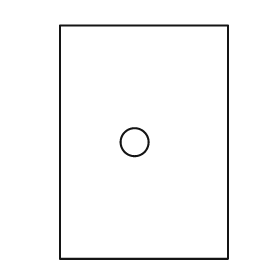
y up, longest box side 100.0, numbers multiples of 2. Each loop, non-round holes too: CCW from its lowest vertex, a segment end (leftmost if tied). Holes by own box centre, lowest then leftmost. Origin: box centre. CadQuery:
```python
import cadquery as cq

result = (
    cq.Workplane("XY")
    .moveTo(-36.0, -50.0)
    .lineTo(36.0, -50.0)
    .lineTo(36.0, 50.0)
    .lineTo(-36.0, 50.0)
    .close()
    .moveTo(-4.0, 0.0)
    .circle(6.0)
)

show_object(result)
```